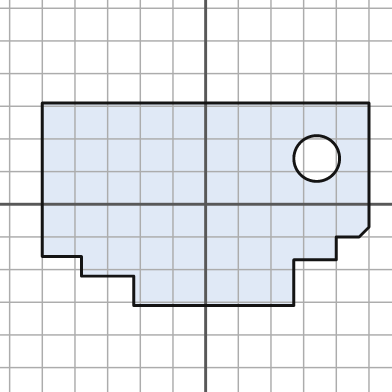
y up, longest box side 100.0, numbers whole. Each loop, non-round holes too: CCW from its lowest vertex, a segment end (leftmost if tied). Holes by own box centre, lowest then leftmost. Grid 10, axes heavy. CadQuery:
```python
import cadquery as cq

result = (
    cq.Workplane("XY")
    .moveTo(-22.0, -31.0)
    .lineTo(27.0, -31.0)
    .lineTo(27.0, -17.0)
    .lineTo(40.0, -17.0)
    .lineTo(40.0, -10.0)
    .lineTo(47.0, -10.0)
    .lineTo(50.0, -7.0)
    .lineTo(50.0, 31.0)
    .lineTo(-50.0, 31.0)
    .lineTo(-50.0, -16.0)
    .lineTo(-38.0, -16.0)
    .lineTo(-38.0, -22.0)
    .lineTo(-22.0, -22.0)
    .close()
    .moveTo(34.0, 14.0)
    .circle(7.0)
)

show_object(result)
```